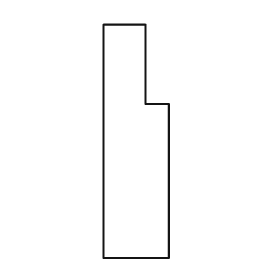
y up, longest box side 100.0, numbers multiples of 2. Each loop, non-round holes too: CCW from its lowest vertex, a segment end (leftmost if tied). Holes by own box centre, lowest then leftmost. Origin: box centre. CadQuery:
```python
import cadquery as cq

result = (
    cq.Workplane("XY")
    .moveTo(-14.0, -50.0)
    .lineTo(14.0, -50.0)
    .lineTo(14.0, 16.0)
    .lineTo(4.0, 16.0)
    .lineTo(4.0, 50.0)
    .lineTo(-14.0, 50.0)
    .close()
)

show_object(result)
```